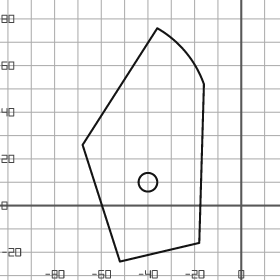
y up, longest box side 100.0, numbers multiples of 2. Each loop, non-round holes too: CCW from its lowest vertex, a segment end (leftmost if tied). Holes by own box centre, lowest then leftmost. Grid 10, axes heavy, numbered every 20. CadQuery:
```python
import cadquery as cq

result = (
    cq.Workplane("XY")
    .moveTo(-52.0, -24.0)
    .lineTo(-18.0, -16.0)
    .lineTo(-16.0, 52.0)
    .threePointArc((-24.0, 66.0), (-36.0, 76.0))
    .lineTo(-68.0, 26.0)
    .close()
    .moveTo(-40.0, 10.0)
    .circle(4.0)
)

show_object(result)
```